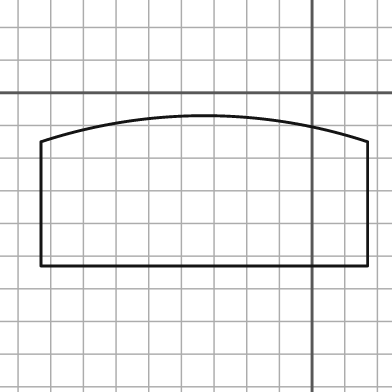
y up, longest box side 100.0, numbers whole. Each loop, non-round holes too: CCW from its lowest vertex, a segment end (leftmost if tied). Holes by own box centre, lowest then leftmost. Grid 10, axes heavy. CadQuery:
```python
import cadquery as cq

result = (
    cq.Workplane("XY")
    .moveTo(-83.0, -53.0)
    .lineTo(17.0, -53.0)
    .lineTo(17.0, -15.0)
    .threePointArc((-33.0, -7.0), (-83.0, -15.0))
    .close()
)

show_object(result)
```